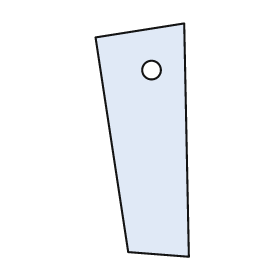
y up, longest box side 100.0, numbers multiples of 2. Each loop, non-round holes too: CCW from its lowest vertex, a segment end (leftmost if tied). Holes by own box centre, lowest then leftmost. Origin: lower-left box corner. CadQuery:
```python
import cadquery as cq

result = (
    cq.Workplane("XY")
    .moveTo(40.0, 0.0)
    .lineTo(38.0, 100.0)
    .lineTo(0.0, 94.0)
    .lineTo(14.0, 2.0)
    .close()
    .moveTo(24.0, 80.0)
    .circle(4.0)
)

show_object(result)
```